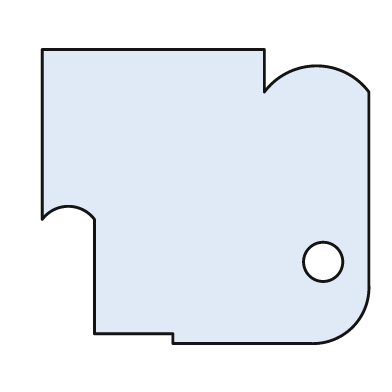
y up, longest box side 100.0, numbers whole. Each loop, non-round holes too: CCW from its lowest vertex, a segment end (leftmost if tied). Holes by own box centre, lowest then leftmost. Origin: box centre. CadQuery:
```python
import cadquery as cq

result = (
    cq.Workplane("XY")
    .moveTo(-10.0, -45.0)
    .lineTo(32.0, -45.0)
    .threePointArc((45.0, -40.0), (50.0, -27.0))
    .lineTo(50.0, 32.0)
    .threePointArc((34.0, 40.0), (18.0, 32.0))
    .lineTo(18.0, 45.0)
    .lineTo(-50.0, 45.0)
    .lineTo(-50.0, -7.0)
    .threePointArc((-42.0, -3.0), (-34.0, -7.0))
    .lineTo(-34.0, -42.0)
    .lineTo(-10.0, -42.0)
    .close()
    .moveTo(36.0, -20.0)
    .circle(6.0)
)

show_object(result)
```